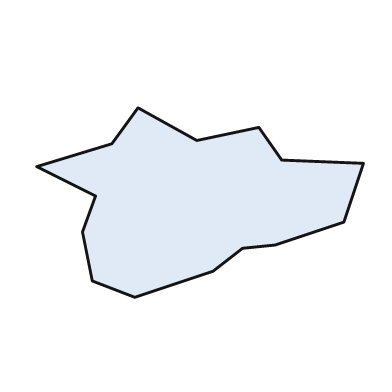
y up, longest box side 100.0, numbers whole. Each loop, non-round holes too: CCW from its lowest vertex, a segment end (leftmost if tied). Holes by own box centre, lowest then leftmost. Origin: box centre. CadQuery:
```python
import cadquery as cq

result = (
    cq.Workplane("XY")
    .moveTo(-20.0, -29.0)
    .lineTo(4.0, -21.0)
    .lineTo(13.0, -14.0)
    .lineTo(23.0, -13.0)
    .lineTo(44.0, -6.0)
    .lineTo(50.0, 12.0)
    .lineTo(25.0, 13.0)
    .lineTo(18.0, 23.0)
    .lineTo(-1.0, 19.0)
    .lineTo(-19.0, 29.0)
    .lineTo(-27.0, 18.0)
    .lineTo(-50.0, 11.0)
    .lineTo(-32.0, 2.0)
    .lineTo(-36.0, -9.0)
    .lineTo(-33.0, -24.0)
    .close()
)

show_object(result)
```